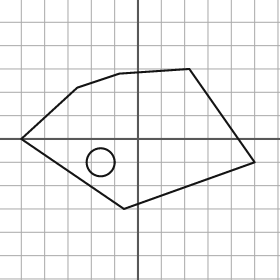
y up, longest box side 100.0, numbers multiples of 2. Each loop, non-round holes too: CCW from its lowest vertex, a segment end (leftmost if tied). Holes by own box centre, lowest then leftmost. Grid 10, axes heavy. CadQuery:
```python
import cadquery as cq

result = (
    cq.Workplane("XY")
    .moveTo(-6.0, -30.0)
    .lineTo(50.0, -10.0)
    .lineTo(22.0, 30.0)
    .lineTo(-8.0, 28.0)
    .lineTo(-26.0, 22.0)
    .lineTo(-50.0, 0.0)
    .close()
    .moveTo(-16.0, -10.0)
    .circle(6.0)
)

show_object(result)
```